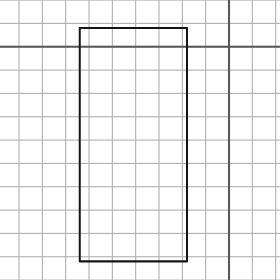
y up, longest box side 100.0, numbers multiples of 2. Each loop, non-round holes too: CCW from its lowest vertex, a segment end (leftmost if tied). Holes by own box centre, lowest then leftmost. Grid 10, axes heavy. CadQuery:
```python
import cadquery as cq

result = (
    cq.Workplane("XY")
    .moveTo(-64.0, -92.0)
    .lineTo(-18.0, -92.0)
    .lineTo(-18.0, 8.0)
    .lineTo(-64.0, 8.0)
    .close()
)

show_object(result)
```